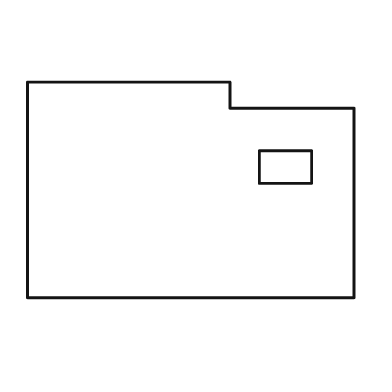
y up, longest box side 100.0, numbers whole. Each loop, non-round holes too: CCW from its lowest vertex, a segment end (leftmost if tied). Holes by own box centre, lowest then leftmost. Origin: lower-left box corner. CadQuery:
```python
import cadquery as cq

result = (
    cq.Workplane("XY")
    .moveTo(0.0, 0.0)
    .lineTo(100.0, 0.0)
    .lineTo(100.0, 58.0)
    .lineTo(62.0, 58.0)
    .lineTo(62.0, 66.0)
    .lineTo(0.0, 66.0)
    .close()
    .moveTo(71.0, 35.0)
    .lineTo(87.0, 35.0)
    .lineTo(87.0, 45.0)
    .lineTo(71.0, 45.0)
    .close()
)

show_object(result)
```